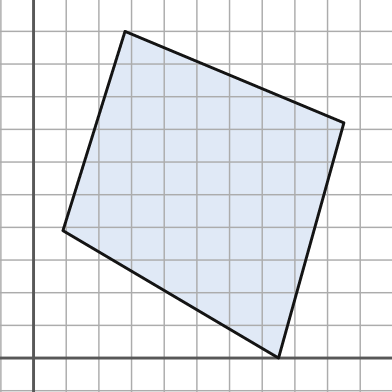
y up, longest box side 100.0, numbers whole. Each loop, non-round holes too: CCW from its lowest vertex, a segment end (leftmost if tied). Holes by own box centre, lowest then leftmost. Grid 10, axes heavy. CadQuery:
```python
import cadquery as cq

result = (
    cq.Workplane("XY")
    .moveTo(75.0, 0.0)
    .lineTo(95.0, 72.0)
    .lineTo(28.0, 100.0)
    .lineTo(9.0, 39.0)
    .close()
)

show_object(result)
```